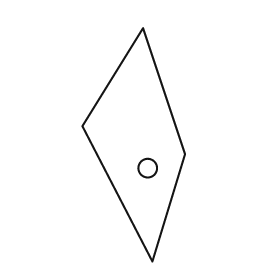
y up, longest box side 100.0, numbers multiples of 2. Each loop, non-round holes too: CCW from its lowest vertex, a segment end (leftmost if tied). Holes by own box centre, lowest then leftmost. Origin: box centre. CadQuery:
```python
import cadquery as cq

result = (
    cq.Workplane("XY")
    .moveTo(8.0, -50.0)
    .lineTo(22.0, -4.0)
    .lineTo(4.0, 50.0)
    .lineTo(-22.0, 8.0)
    .close()
    .moveTo(6.0, -10.0)
    .circle(4.0)
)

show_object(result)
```